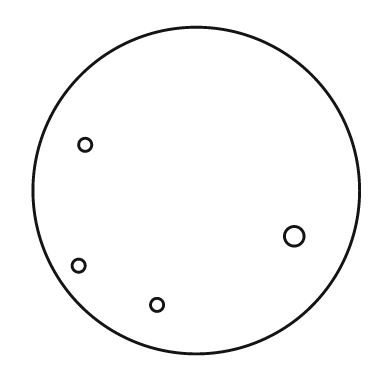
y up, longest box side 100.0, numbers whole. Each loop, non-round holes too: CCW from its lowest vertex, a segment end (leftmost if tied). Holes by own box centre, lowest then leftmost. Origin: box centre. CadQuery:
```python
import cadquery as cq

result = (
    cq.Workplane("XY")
    .moveTo(0.0, 0.0)
    .circle(50.0)
    .moveTo(-12.0, -35.0)
    .circle(2.0)
    .moveTo(-36.0, -23.0)
    .circle(2.0)
    .moveTo(30.0, -14.0)
    .circle(3.0)
    .moveTo(-34.0, 14.0)
    .circle(2.0)
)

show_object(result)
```